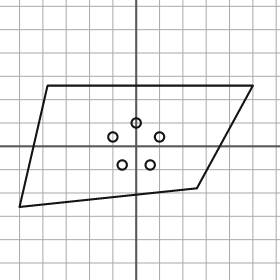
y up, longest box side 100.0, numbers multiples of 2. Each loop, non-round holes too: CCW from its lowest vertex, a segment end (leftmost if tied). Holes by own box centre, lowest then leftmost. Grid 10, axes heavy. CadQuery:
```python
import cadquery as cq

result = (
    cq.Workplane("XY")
    .moveTo(-50.0, -26.0)
    .lineTo(26.0, -18.0)
    .lineTo(50.0, 26.0)
    .lineTo(-38.0, 26.0)
    .close()
    .moveTo(-6.0, -8.0)
    .circle(2.0)
    .moveTo(6.0, -8.0)
    .circle(2.0)
    .moveTo(-10.0, 4.0)
    .circle(2.0)
    .moveTo(10.0, 4.0)
    .circle(2.0)
    .moveTo(0.0, 10.0)
    .circle(2.0)
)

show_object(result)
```